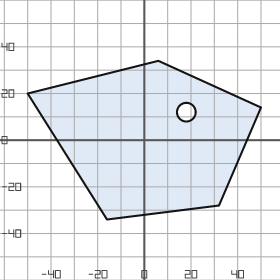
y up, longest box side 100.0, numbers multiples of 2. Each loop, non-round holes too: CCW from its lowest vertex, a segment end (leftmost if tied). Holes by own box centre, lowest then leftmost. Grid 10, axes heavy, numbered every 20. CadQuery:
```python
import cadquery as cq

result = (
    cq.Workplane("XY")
    .moveTo(-16.0, -34.0)
    .lineTo(32.0, -28.0)
    .lineTo(50.0, 14.0)
    .lineTo(6.0, 34.0)
    .lineTo(-50.0, 20.0)
    .close()
    .moveTo(18.0, 12.0)
    .circle(4.0)
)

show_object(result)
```